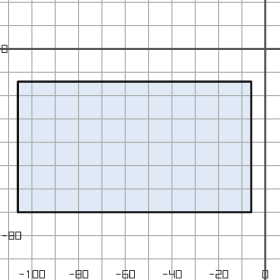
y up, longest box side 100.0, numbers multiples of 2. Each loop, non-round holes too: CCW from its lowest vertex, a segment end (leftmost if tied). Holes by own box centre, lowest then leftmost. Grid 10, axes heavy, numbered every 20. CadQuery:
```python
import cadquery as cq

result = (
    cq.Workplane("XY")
    .moveTo(-106.0, -70.0)
    .lineTo(-6.0, -70.0)
    .lineTo(-6.0, -14.0)
    .lineTo(-106.0, -14.0)
    .close()
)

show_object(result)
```